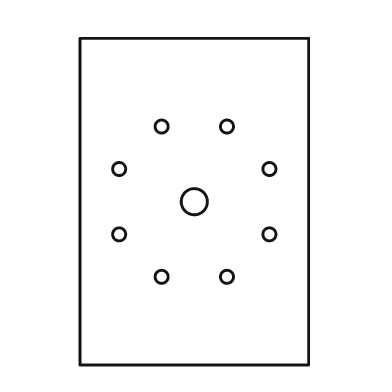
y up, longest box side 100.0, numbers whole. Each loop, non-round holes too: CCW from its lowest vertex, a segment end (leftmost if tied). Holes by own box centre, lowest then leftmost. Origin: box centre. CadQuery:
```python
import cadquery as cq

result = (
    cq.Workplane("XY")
    .moveTo(-35.0, -50.0)
    .lineTo(35.0, -50.0)
    .lineTo(35.0, 50.0)
    .lineTo(-35.0, 50.0)
    .close()
    .moveTo(-10.0, -23.0)
    .circle(2.0)
    .moveTo(10.0, -23.0)
    .circle(2.0)
    .moveTo(-23.0, -10.0)
    .circle(2.0)
    .moveTo(23.0, -10.0)
    .circle(2.0)
    .moveTo(0.0, 0.0)
    .circle(4.0)
    .moveTo(-23.0, 10.0)
    .circle(2.0)
    .moveTo(23.0, 10.0)
    .circle(2.0)
    .moveTo(-10.0, 23.0)
    .circle(2.0)
    .moveTo(10.0, 23.0)
    .circle(2.0)
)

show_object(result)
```